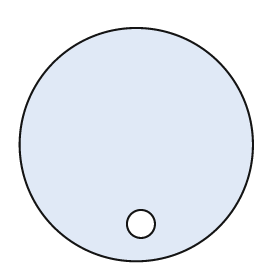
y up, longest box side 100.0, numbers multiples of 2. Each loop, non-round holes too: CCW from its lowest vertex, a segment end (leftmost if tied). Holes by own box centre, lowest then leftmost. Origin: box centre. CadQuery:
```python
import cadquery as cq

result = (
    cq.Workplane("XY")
    .moveTo(0.0, 0.0)
    .circle(50.0)
    .moveTo(2.0, -34.0)
    .circle(6.0)
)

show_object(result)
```